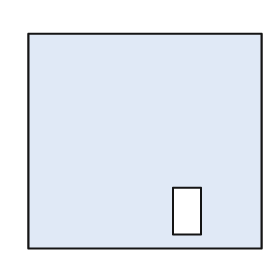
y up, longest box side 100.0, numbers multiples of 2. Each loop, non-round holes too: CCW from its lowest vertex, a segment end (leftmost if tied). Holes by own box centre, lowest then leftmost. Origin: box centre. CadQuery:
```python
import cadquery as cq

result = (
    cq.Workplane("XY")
    .moveTo(-50.0, -46.0)
    .lineTo(50.0, -46.0)
    .lineTo(50.0, 46.0)
    .lineTo(-50.0, 46.0)
    .close()
    .moveTo(12.0, -40.0)
    .lineTo(24.0, -40.0)
    .lineTo(24.0, -20.0)
    .lineTo(12.0, -20.0)
    .close()
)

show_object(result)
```